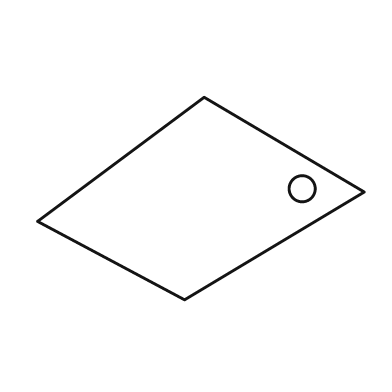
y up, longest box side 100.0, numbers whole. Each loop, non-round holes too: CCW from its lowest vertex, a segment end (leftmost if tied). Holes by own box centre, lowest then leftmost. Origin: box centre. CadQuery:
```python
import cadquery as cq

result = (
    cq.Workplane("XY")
    .moveTo(-5.0, -31.0)
    .lineTo(50.0, 2.0)
    .lineTo(1.0, 31.0)
    .lineTo(-50.0, -7.0)
    .close()
    .moveTo(31.0, 3.0)
    .circle(4.0)
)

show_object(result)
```